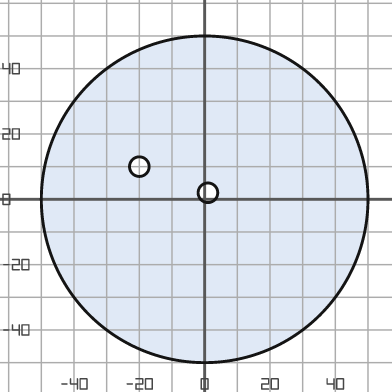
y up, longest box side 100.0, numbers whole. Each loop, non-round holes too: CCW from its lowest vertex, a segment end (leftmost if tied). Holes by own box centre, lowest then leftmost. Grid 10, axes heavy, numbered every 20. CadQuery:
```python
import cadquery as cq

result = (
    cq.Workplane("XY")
    .moveTo(0.0, 0.0)
    .circle(50.0)
    .moveTo(1.0, 2.0)
    .circle(3.0)
    .moveTo(-20.0, 10.0)
    .circle(3.0)
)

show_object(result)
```